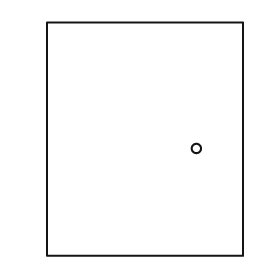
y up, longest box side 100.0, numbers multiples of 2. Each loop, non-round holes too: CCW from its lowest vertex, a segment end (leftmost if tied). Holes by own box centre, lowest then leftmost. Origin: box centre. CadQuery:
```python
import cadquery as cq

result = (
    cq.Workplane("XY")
    .moveTo(-42.0, -50.0)
    .lineTo(42.0, -50.0)
    .lineTo(42.0, 50.0)
    .lineTo(-42.0, 50.0)
    .close()
    .moveTo(22.0, -4.0)
    .circle(2.0)
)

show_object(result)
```